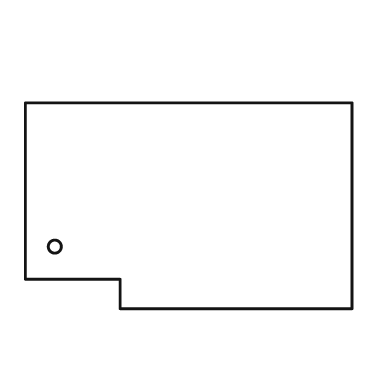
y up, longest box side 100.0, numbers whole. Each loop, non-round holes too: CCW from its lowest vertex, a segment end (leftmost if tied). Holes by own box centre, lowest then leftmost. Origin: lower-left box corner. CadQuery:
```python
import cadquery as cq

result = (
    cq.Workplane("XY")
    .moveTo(29.0, 0.0)
    .lineTo(100.0, 0.0)
    .lineTo(100.0, 63.0)
    .lineTo(0.0, 63.0)
    .lineTo(0.0, 9.0)
    .lineTo(29.0, 9.0)
    .close()
    .moveTo(9.0, 19.0)
    .circle(2.0)
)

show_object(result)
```